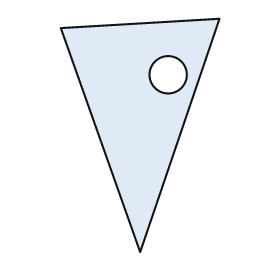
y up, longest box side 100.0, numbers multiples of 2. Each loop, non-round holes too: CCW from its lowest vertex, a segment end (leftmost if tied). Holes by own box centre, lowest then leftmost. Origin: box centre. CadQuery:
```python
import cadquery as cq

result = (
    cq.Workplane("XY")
    .moveTo(0.0, -50.0)
    .lineTo(34.0, 50.0)
    .lineTo(-34.0, 46.0)
    .close()
    .moveTo(12.0, 26.0)
    .circle(8.0)
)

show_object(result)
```